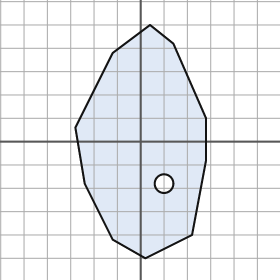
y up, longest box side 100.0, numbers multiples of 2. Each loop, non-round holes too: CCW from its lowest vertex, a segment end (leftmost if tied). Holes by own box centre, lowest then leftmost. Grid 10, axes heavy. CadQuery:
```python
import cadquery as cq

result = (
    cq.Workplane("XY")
    .moveTo(2.0, -50.0)
    .lineTo(22.0, -40.0)
    .lineTo(28.0, -8.0)
    .lineTo(28.0, 10.0)
    .lineTo(14.0, 42.0)
    .lineTo(4.0, 50.0)
    .lineTo(-12.0, 38.0)
    .lineTo(-28.0, 6.0)
    .lineTo(-24.0, -18.0)
    .lineTo(-12.0, -42.0)
    .close()
    .moveTo(10.0, -18.0)
    .circle(4.0)
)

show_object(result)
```